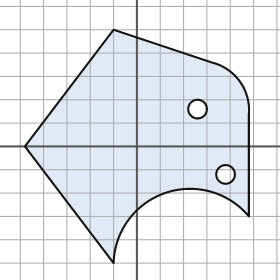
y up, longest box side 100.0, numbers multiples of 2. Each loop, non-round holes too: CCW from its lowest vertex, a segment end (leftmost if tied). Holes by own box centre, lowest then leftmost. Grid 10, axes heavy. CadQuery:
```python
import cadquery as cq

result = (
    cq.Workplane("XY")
    .moveTo(-10.0, -50.0)
    .threePointArc((12.0, -20.0), (48.0, -30.0))
    .lineTo(48.0, 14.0)
    .threePointArc((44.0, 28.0), (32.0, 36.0))
    .lineTo(-10.0, 50.0)
    .lineTo(-48.0, 0.0)
    .close()
    .moveTo(38.0, -12.0)
    .circle(4.0)
    .moveTo(26.0, 16.0)
    .circle(4.0)
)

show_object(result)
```